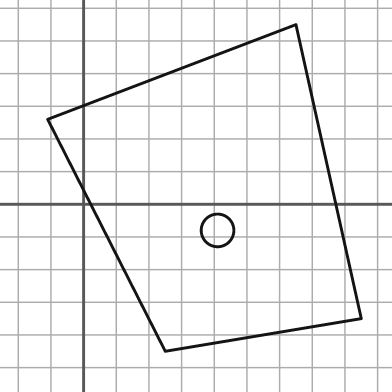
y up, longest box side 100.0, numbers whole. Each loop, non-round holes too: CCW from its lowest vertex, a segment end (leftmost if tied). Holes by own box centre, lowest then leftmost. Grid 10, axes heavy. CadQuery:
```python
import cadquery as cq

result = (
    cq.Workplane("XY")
    .moveTo(25.0, -45.0)
    .lineTo(85.0, -35.0)
    .lineTo(65.0, 55.0)
    .lineTo(-11.0, 26.0)
    .close()
    .moveTo(41.0, -8.0)
    .circle(5.0)
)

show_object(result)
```